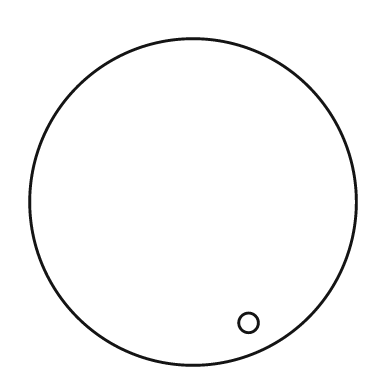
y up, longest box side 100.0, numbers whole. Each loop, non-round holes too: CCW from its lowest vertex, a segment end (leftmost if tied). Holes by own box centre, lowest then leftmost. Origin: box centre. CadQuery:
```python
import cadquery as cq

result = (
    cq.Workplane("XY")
    .moveTo(0.0, 0.0)
    .circle(50.0)
    .moveTo(17.0, -37.0)
    .circle(3.0)
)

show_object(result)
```